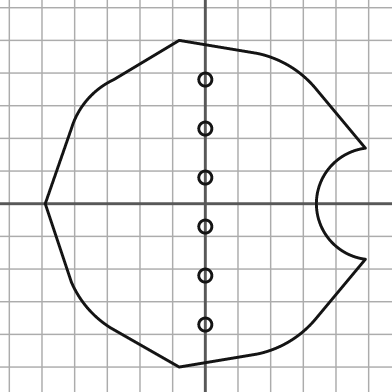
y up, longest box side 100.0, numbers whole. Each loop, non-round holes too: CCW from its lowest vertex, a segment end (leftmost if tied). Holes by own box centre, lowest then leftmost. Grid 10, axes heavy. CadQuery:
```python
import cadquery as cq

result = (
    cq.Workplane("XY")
    .moveTo(-8.0, -50.0)
    .lineTo(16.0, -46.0)
    .threePointArc((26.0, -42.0), (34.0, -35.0))
    .lineTo(49.0, -17.0)
    .threePointArc((34.0, 0.0), (49.0, 17.0))
    .lineTo(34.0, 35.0)
    .threePointArc((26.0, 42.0), (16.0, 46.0))
    .lineTo(-8.0, 50.0)
    .lineTo(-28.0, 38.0)
    .threePointArc((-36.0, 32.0), (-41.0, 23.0))
    .lineTo(-49.0, 0.0)
    .lineTo(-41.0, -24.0)
    .threePointArc((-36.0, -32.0), (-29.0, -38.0))
    .close()
    .moveTo(0.0, -37.0)
    .circle(2.0)
    .moveTo(0.0, -22.0)
    .circle(2.0)
    .moveTo(0.0, -7.0)
    .circle(2.0)
    .moveTo(0.0, 8.0)
    .circle(2.0)
    .moveTo(0.0, 23.0)
    .circle(2.0)
    .moveTo(0.0, 38.0)
    .circle(2.0)
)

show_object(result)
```